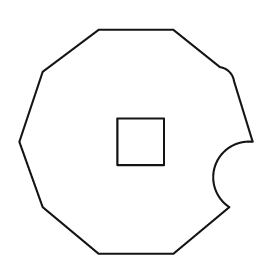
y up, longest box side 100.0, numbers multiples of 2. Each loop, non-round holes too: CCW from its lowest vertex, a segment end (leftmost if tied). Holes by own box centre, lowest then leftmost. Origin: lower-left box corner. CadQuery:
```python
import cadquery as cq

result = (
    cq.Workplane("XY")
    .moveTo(34.0, 0.0)
    .lineTo(66.0, 0.0)
    .lineTo(90.0, 20.0)
    .threePointArc((84.0, 38.0), (100.0, 48.0))
    .lineTo(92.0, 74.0)
    .threePointArc((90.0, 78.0), (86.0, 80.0))
    .lineTo(66.0, 96.0)
    .lineTo(34.0, 96.0)
    .lineTo(10.0, 78.0)
    .lineTo(0.0, 48.0)
    .lineTo(10.0, 20.0)
    .close()
    .moveTo(42.0, 38.0)
    .lineTo(62.0, 38.0)
    .lineTo(62.0, 58.0)
    .lineTo(42.0, 58.0)
    .close()
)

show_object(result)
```